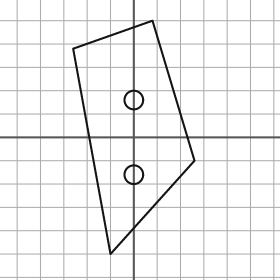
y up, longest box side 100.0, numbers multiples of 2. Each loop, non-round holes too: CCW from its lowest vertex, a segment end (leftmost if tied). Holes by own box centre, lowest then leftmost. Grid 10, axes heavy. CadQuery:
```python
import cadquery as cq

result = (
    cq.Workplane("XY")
    .moveTo(-10.0, -50.0)
    .lineTo(26.0, -10.0)
    .lineTo(8.0, 50.0)
    .lineTo(-26.0, 38.0)
    .close()
    .moveTo(0.0, -16.0)
    .circle(4.0)
    .moveTo(0.0, 16.0)
    .circle(4.0)
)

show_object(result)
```